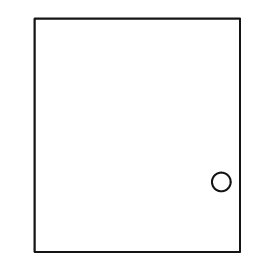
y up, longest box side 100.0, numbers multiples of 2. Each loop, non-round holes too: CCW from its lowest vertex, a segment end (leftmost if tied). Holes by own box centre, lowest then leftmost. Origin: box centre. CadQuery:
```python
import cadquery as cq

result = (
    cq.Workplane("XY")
    .moveTo(-44.0, -50.0)
    .lineTo(44.0, -50.0)
    .lineTo(44.0, 50.0)
    .lineTo(-44.0, 50.0)
    .close()
    .moveTo(36.0, -20.0)
    .circle(4.0)
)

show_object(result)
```